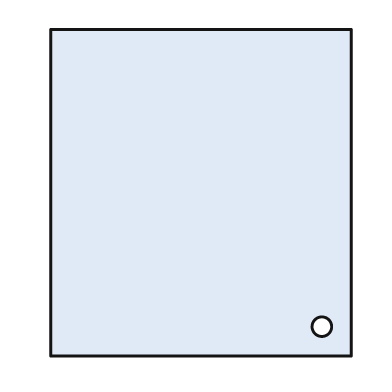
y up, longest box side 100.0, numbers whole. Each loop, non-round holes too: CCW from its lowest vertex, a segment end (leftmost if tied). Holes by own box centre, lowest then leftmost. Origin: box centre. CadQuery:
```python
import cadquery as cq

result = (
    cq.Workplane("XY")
    .moveTo(-46.0, -50.0)
    .lineTo(46.0, -50.0)
    .lineTo(46.0, 50.0)
    .lineTo(-46.0, 50.0)
    .close()
    .moveTo(37.0, -41.0)
    .circle(3.0)
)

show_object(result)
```